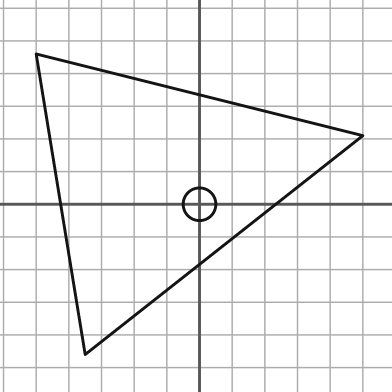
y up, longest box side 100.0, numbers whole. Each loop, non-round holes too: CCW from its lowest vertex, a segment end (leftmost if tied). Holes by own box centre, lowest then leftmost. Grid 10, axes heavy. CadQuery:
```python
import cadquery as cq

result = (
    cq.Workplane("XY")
    .moveTo(-35.0, -46.0)
    .lineTo(50.0, 21.0)
    .lineTo(-50.0, 46.0)
    .close()
    .moveTo(0.0, 0.0)
    .circle(5.0)
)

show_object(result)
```